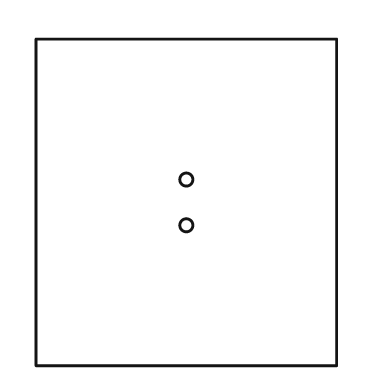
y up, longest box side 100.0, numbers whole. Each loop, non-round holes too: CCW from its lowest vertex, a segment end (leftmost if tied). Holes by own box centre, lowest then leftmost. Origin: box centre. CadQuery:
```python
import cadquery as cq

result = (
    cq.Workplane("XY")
    .moveTo(-46.0, -50.0)
    .lineTo(46.0, -50.0)
    .lineTo(46.0, 50.0)
    .lineTo(-46.0, 50.0)
    .close()
    .moveTo(0.0, -7.0)
    .circle(2.0)
    .moveTo(0.0, 7.0)
    .circle(2.0)
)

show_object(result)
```